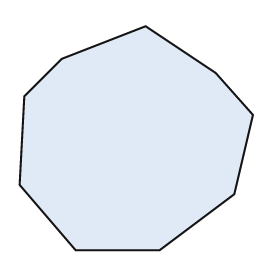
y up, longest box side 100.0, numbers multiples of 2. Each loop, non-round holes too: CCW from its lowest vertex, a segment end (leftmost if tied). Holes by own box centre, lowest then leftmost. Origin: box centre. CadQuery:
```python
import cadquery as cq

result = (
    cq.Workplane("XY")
    .moveTo(-26.0, -48.0)
    .lineTo(10.0, -48.0)
    .lineTo(42.0, -24.0)
    .lineTo(50.0, 10.0)
    .lineTo(34.0, 28.0)
    .lineTo(4.0, 48.0)
    .lineTo(-32.0, 34.0)
    .lineTo(-48.0, 18.0)
    .lineTo(-50.0, -20.0)
    .close()
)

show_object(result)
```